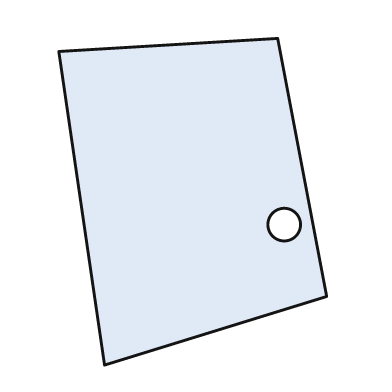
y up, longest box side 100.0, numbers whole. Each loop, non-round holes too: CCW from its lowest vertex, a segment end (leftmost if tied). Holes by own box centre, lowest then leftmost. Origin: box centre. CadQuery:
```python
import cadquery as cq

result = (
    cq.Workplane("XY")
    .moveTo(-27.0, -50.0)
    .lineTo(41.0, -29.0)
    .lineTo(26.0, 50.0)
    .lineTo(-41.0, 46.0)
    .close()
    .moveTo(28.0, -7.0)
    .circle(5.0)
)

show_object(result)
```